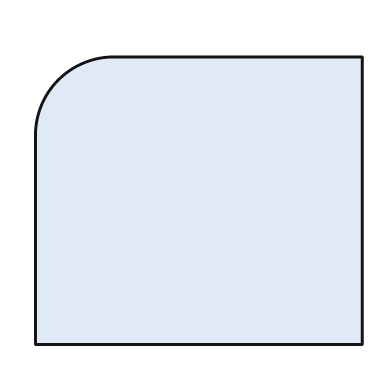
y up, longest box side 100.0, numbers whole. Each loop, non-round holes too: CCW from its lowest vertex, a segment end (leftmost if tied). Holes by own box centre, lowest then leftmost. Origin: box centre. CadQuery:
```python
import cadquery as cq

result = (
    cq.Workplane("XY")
    .moveTo(-50.0, -44.0)
    .lineTo(50.0, -44.0)
    .lineTo(50.0, 44.0)
    .lineTo(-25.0, 44.0)
    .threePointArc((-43.0, 37.0), (-50.0, 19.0))
    .close()
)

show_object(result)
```